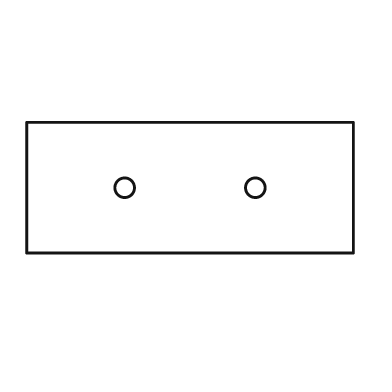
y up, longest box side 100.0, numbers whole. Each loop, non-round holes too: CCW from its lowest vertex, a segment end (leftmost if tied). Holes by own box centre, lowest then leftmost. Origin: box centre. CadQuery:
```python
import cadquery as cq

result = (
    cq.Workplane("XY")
    .moveTo(-50.0, -20.0)
    .lineTo(50.0, -20.0)
    .lineTo(50.0, 20.0)
    .lineTo(-50.0, 20.0)
    .close()
    .moveTo(-20.0, 0.0)
    .circle(3.0)
    .moveTo(20.0, 0.0)
    .circle(3.0)
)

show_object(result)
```